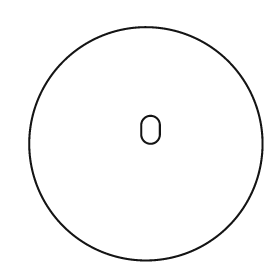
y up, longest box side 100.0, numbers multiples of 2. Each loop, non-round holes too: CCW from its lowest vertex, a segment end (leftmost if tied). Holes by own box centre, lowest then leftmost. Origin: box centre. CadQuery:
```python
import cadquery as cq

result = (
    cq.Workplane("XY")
    .moveTo(0.0, 0.0)
    .circle(50.0)
    .moveTo(-2.0, 4.0)
    .threePointArc((2.0, 0.0), (6.0, 4.0))
    .lineTo(6.0, 8.0)
    .threePointArc((2.0, 12.0), (-2.0, 8.0))
    .close()
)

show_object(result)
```